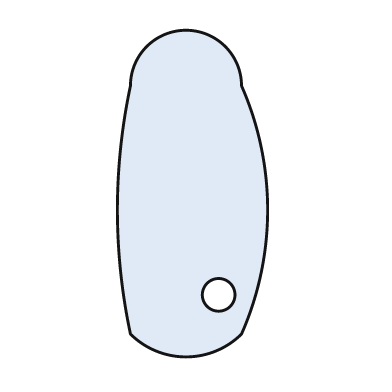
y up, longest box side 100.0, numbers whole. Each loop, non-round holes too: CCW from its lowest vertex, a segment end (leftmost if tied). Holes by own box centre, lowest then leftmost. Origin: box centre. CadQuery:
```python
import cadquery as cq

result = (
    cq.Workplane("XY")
    .moveTo(-19.0, -43.0)
    .threePointArc((-2.0, -50.0), (15.0, -43.0))
    .threePointArc((23.0, -5.0), (15.0, 33.0))
    .threePointArc((-2.0, 50.0), (-19.0, 33.0))
    .threePointArc((-23.0, -5.0), (-19.0, -43.0))
    .close()
    .moveTo(8.0, -31.0)
    .circle(5.0)
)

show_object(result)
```